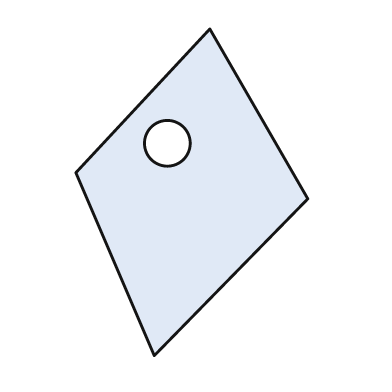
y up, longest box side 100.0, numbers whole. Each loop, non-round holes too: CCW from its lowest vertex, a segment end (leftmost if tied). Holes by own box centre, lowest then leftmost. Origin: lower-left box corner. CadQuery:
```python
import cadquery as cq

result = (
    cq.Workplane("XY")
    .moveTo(24.0, 0.0)
    .lineTo(71.0, 48.0)
    .lineTo(41.0, 100.0)
    .lineTo(0.0, 56.0)
    .close()
    .moveTo(28.0, 65.0)
    .circle(7.0)
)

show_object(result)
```